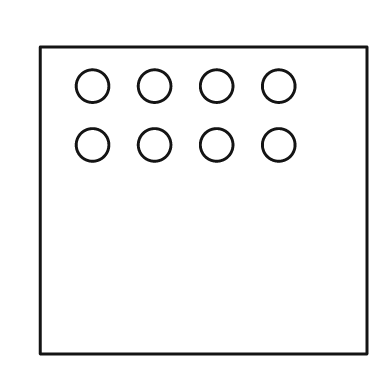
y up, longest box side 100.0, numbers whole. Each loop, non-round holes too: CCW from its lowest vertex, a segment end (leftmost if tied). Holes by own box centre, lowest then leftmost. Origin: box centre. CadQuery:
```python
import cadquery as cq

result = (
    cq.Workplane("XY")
    .moveTo(-50.0, -47.0)
    .lineTo(50.0, -47.0)
    .lineTo(50.0, 47.0)
    .lineTo(-50.0, 47.0)
    .close()
    .moveTo(-34.0, 17.0)
    .circle(5.0)
    .moveTo(-15.0, 17.0)
    .circle(5.0)
    .moveTo(4.0, 17.0)
    .circle(5.0)
    .moveTo(23.0, 17.0)
    .circle(5.0)
    .moveTo(-34.0, 35.0)
    .circle(5.0)
    .moveTo(-15.0, 35.0)
    .circle(5.0)
    .moveTo(4.0, 35.0)
    .circle(5.0)
    .moveTo(23.0, 35.0)
    .circle(5.0)
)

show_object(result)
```